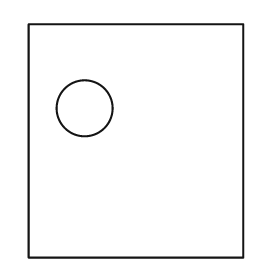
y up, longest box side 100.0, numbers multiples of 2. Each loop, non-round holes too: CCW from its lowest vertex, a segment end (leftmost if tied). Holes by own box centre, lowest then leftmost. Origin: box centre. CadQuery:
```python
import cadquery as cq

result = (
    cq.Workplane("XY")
    .moveTo(-46.0, -50.0)
    .lineTo(46.0, -50.0)
    .lineTo(46.0, 50.0)
    .lineTo(-46.0, 50.0)
    .close()
    .moveTo(-22.0, 14.0)
    .circle(12.0)
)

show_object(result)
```